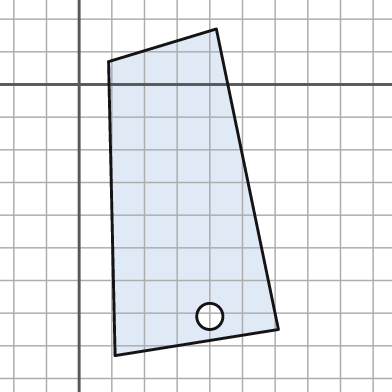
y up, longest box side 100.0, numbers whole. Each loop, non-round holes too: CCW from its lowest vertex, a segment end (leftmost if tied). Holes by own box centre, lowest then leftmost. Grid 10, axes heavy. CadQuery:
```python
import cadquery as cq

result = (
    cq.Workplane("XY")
    .moveTo(11.0, -83.0)
    .lineTo(61.0, -75.0)
    .lineTo(42.0, 17.0)
    .lineTo(9.0, 7.0)
    .close()
    .moveTo(40.0, -71.0)
    .circle(4.0)
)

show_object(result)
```